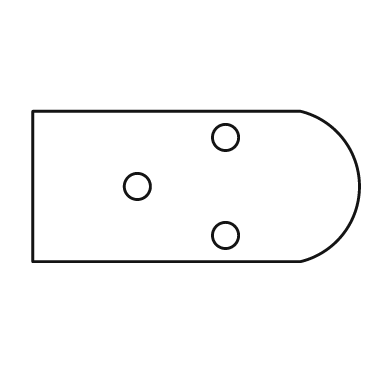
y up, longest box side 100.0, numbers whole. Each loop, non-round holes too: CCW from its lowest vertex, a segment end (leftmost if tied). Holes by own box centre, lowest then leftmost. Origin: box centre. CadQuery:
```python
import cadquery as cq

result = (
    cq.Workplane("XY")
    .moveTo(-50.0, -23.0)
    .lineTo(32.0, -23.0)
    .threePointArc((50.0, 0.0), (32.0, 23.0))
    .lineTo(-50.0, 23.0)
    .close()
    .moveTo(9.0, -15.0)
    .circle(4.0)
    .moveTo(-18.0, 0.0)
    .circle(4.0)
    .moveTo(9.0, 15.0)
    .circle(4.0)
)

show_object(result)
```